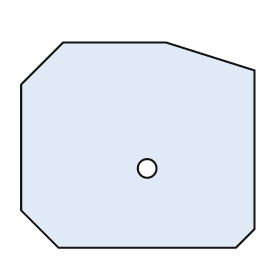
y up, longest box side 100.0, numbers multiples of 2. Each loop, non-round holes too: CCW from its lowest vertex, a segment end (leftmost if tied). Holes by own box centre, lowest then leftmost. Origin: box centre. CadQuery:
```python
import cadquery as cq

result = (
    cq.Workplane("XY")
    .moveTo(-34.0, -44.0)
    .lineTo(42.0, -44.0)
    .lineTo(50.0, -36.0)
    .lineTo(50.0, 32.0)
    .lineTo(12.0, 44.0)
    .lineTo(-32.0, 44.0)
    .lineTo(-50.0, 26.0)
    .lineTo(-50.0, -28.0)
    .close()
    .moveTo(4.0, -10.0)
    .circle(4.0)
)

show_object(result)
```